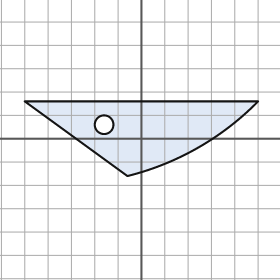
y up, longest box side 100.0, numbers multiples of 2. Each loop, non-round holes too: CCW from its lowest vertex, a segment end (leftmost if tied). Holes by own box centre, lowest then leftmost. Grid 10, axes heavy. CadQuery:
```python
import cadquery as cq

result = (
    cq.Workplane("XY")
    .moveTo(-6.0, -16.0)
    .threePointArc((24.0, -4.0), (50.0, 16.0))
    .lineTo(-50.0, 16.0)
    .close()
    .moveTo(-16.0, 6.0)
    .circle(4.0)
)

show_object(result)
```